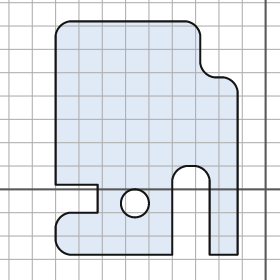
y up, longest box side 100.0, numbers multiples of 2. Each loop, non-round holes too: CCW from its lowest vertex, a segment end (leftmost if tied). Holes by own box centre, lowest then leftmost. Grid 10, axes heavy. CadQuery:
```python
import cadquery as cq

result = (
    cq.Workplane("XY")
    .moveTo(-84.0, -28.0)
    .lineTo(-40.0, -28.0)
    .lineTo(-40.0, 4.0)
    .threePointArc((-38.0, 8.0), (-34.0, 10.0))
    .lineTo(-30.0, 10.0)
    .threePointArc((-26.0, 8.0), (-24.0, 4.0))
    .lineTo(-24.0, -28.0)
    .lineTo(-12.0, -28.0)
    .lineTo(-12.0, 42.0)
    .threePointArc((-14.0, 46.0), (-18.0, 48.0))
    .lineTo(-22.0, 48.0)
    .threePointArc((-26.0, 50.0), (-28.0, 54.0))
    .lineTo(-28.0, 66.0)
    .threePointArc((-30.0, 70.0), (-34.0, 72.0))
    .lineTo(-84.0, 72.0)
    .threePointArc((-88.0, 70.0), (-90.0, 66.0))
    .lineTo(-90.0, 2.0)
    .lineTo(-72.0, 2.0)
    .lineTo(-72.0, -10.0)
    .lineTo(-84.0, -10.0)
    .threePointArc((-88.0, -12.0), (-90.0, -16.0))
    .lineTo(-90.0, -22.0)
    .threePointArc((-88.0, -26.0), (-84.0, -28.0))
    .close()
    .moveTo(-56.0, -6.0)
    .circle(6.0)
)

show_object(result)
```